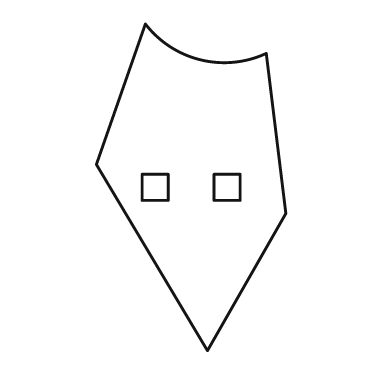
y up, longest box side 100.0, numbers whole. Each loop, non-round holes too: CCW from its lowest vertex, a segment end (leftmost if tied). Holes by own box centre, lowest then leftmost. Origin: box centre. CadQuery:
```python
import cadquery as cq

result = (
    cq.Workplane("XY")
    .moveTo(5.0, -50.0)
    .lineTo(29.0, -8.0)
    .lineTo(23.0, 41.0)
    .threePointArc((3.0, 39.0), (-14.0, 50.0))
    .lineTo(-29.0, 7.0)
    .close()
    .moveTo(-15.0, -4.0)
    .lineTo(-7.0, -4.0)
    .lineTo(-7.0, 4.0)
    .lineTo(-15.0, 4.0)
    .close()
    .moveTo(7.0, -4.0)
    .lineTo(15.0, -4.0)
    .lineTo(15.0, 4.0)
    .lineTo(7.0, 4.0)
    .close()
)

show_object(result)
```